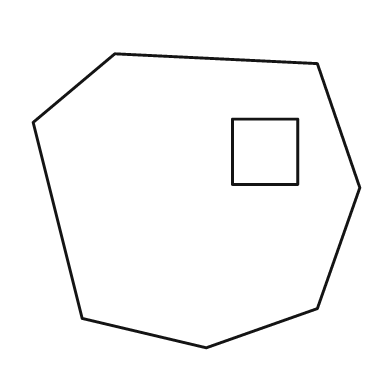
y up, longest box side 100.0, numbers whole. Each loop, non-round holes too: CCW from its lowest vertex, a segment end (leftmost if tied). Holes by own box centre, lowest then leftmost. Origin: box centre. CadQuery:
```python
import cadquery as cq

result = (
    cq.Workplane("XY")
    .moveTo(3.0, -45.0)
    .lineTo(37.0, -33.0)
    .lineTo(50.0, 4.0)
    .lineTo(37.0, 42.0)
    .lineTo(-25.0, 45.0)
    .lineTo(-50.0, 24.0)
    .lineTo(-35.0, -36.0)
    .close()
    .moveTo(11.0, 5.0)
    .lineTo(31.0, 5.0)
    .lineTo(31.0, 25.0)
    .lineTo(11.0, 25.0)
    .close()
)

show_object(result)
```